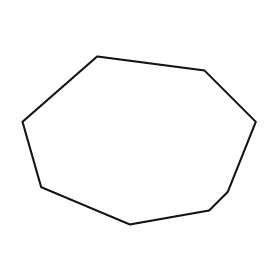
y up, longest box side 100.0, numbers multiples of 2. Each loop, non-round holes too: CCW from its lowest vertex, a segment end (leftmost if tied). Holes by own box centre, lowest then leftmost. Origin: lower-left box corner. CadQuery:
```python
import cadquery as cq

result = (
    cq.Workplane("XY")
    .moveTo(46.0, 0.0)
    .lineTo(80.0, 6.0)
    .lineTo(88.0, 14.0)
    .lineTo(100.0, 44.0)
    .lineTo(78.0, 66.0)
    .lineTo(32.0, 72.0)
    .lineTo(0.0, 44.0)
    .lineTo(8.0, 16.0)
    .close()
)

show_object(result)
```